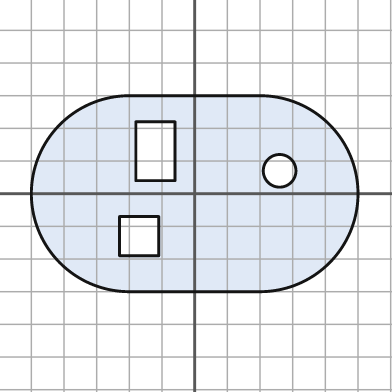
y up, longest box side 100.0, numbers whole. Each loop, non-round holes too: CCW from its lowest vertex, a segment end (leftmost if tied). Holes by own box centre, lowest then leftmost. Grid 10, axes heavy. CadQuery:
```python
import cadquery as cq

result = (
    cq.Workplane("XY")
    .moveTo(-20.0, -30.0)
    .lineTo(20.0, -30.0)
    .threePointArc((50.0, 0.0), (20.0, 30.0))
    .lineTo(-20.0, 30.0)
    .threePointArc((-50.0, 0.0), (-20.0, -30.0))
    .close()
    .moveTo(-23.0, -19.0)
    .lineTo(-11.0, -19.0)
    .lineTo(-11.0, -7.0)
    .lineTo(-23.0, -7.0)
    .close()
    .moveTo(26.0, 7.0)
    .circle(5.0)
    .moveTo(-18.0, 4.0)
    .lineTo(-6.0, 4.0)
    .lineTo(-6.0, 22.0)
    .lineTo(-18.0, 22.0)
    .close()
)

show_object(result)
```